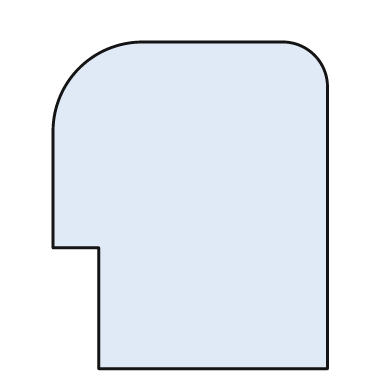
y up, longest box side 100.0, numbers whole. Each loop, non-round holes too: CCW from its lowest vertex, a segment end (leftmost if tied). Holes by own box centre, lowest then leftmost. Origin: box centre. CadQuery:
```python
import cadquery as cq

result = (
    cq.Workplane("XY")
    .moveTo(-28.0, -50.0)
    .lineTo(42.0, -50.0)
    .lineTo(42.0, 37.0)
    .threePointArc((38.0, 46.0), (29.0, 50.0))
    .lineTo(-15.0, 50.0)
    .threePointArc((-34.0, 42.0), (-42.0, 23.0))
    .lineTo(-42.0, -13.0)
    .lineTo(-28.0, -13.0)
    .close()
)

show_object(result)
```